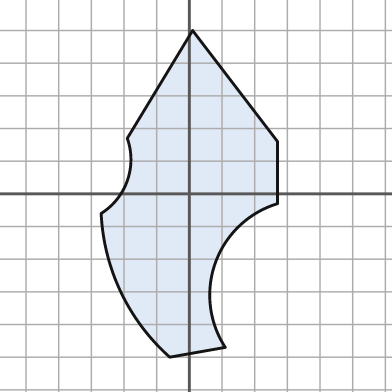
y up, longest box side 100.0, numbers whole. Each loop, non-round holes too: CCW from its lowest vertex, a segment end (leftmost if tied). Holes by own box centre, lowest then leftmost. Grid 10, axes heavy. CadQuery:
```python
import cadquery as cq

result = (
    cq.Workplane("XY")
    .moveTo(-6.0, -50.0)
    .lineTo(11.0, -47.0)
    .threePointArc((8.0, -21.0), (27.0, -3.0))
    .lineTo(27.0, 16.0)
    .lineTo(1.0, 50.0)
    .lineTo(-19.0, 17.0)
    .threePointArc((-19.0, 4.0), (-27.0, -6.0))
    .threePointArc((-21.0, -30.0), (-6.0, -50.0))
    .close()
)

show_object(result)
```